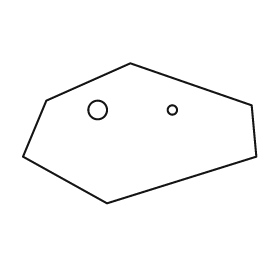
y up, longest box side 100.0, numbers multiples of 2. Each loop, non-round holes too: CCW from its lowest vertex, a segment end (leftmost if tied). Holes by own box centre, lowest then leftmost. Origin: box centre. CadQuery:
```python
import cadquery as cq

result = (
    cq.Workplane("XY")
    .moveTo(-14.0, -30.0)
    .lineTo(50.0, -10.0)
    .lineTo(48.0, 12.0)
    .lineTo(-4.0, 30.0)
    .lineTo(-40.0, 14.0)
    .lineTo(-50.0, -10.0)
    .close()
    .moveTo(-18.0, 10.0)
    .circle(4.0)
    .moveTo(14.0, 10.0)
    .circle(2.0)
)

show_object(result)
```